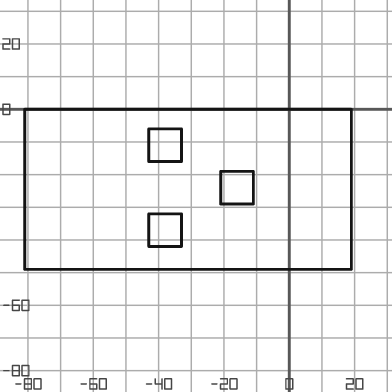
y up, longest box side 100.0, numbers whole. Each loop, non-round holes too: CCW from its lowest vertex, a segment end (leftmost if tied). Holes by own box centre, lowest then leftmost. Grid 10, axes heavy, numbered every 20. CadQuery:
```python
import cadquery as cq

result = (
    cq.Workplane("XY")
    .moveTo(-81.0, -49.0)
    .lineTo(19.0, -49.0)
    .lineTo(19.0, 0.0)
    .lineTo(-81.0, 0.0)
    .close()
    .moveTo(-43.0, -42.0)
    .lineTo(-33.0, -42.0)
    .lineTo(-33.0, -32.0)
    .lineTo(-43.0, -32.0)
    .close()
    .moveTo(-21.0, -29.0)
    .lineTo(-11.0, -29.0)
    .lineTo(-11.0, -19.0)
    .lineTo(-21.0, -19.0)
    .close()
    .moveTo(-43.0, -16.0)
    .lineTo(-33.0, -16.0)
    .lineTo(-33.0, -6.0)
    .lineTo(-43.0, -6.0)
    .close()
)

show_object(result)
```